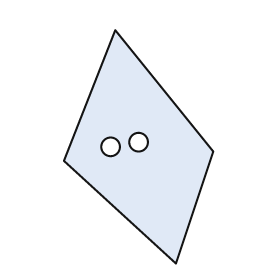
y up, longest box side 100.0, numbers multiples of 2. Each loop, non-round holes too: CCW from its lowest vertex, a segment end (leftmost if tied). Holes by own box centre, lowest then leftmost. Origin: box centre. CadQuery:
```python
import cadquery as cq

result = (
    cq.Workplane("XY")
    .moveTo(16.0, -50.0)
    .lineTo(32.0, -2.0)
    .lineTo(-10.0, 50.0)
    .lineTo(-32.0, -6.0)
    .close()
    .moveTo(-12.0, 0.0)
    .circle(4.0)
    .moveTo(0.0, 2.0)
    .circle(4.0)
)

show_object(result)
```